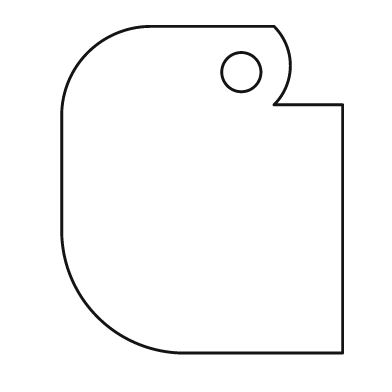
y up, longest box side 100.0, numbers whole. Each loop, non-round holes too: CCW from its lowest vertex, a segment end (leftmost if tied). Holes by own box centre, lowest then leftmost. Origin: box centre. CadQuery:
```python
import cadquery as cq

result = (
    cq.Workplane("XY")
    .moveTo(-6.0, -50.0)
    .lineTo(43.0, -50.0)
    .lineTo(43.0, 26.0)
    .lineTo(22.0, 26.0)
    .threePointArc((27.0, 38.0), (22.0, 50.0))
    .lineTo(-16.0, 50.0)
    .threePointArc((-35.0, 42.0), (-43.0, 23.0))
    .lineTo(-43.0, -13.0)
    .threePointArc((-32.0, -39.0), (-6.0, -50.0))
    .close()
    .moveTo(12.0, 36.0)
    .circle(6.0)
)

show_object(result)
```